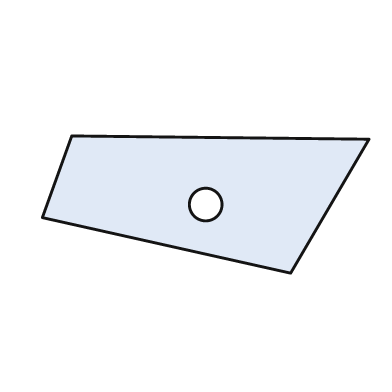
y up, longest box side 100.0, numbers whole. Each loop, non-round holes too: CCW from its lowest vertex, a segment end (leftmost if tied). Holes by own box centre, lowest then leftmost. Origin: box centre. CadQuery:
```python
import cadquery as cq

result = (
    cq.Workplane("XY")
    .moveTo(26.0, -21.0)
    .lineTo(50.0, 20.0)
    .lineTo(-41.0, 21.0)
    .lineTo(-50.0, -4.0)
    .close()
    .moveTo(0.0, 0.0)
    .circle(5.0)
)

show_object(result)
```